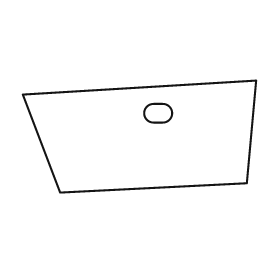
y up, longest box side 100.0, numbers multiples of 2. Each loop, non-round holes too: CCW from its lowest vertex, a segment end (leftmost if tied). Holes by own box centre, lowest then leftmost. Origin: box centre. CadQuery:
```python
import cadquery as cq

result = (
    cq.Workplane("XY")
    .moveTo(-34.0, -24.0)
    .lineTo(46.0, -20.0)
    .lineTo(50.0, 24.0)
    .lineTo(-50.0, 18.0)
    .close()
    .moveTo(6.0, 6.0)
    .lineTo(10.0, 6.0)
    .threePointArc((14.0, 10.0), (10.0, 14.0))
    .lineTo(6.0, 14.0)
    .threePointArc((2.0, 10.0), (6.0, 6.0))
    .close()
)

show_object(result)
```